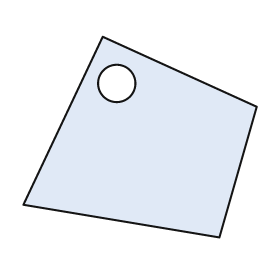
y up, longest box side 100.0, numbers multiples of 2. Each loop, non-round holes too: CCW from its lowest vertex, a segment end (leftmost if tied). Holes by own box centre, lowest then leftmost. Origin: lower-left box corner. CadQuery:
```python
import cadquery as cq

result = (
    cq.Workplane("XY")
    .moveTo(84.0, 0.0)
    .lineTo(100.0, 56.0)
    .lineTo(34.0, 86.0)
    .lineTo(0.0, 14.0)
    .close()
    .moveTo(40.0, 66.0)
    .circle(8.0)
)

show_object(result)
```